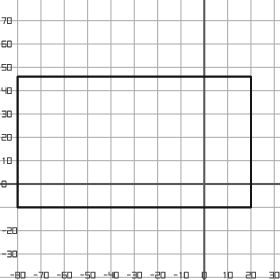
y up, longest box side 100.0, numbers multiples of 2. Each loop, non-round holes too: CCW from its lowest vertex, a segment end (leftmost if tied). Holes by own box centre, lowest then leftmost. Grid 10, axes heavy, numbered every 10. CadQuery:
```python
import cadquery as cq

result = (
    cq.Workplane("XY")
    .moveTo(-80.0, -10.0)
    .lineTo(20.0, -10.0)
    .lineTo(20.0, 46.0)
    .lineTo(-80.0, 46.0)
    .close()
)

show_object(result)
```